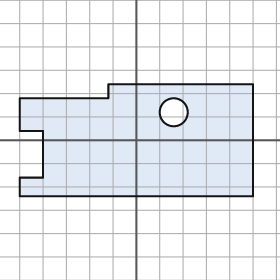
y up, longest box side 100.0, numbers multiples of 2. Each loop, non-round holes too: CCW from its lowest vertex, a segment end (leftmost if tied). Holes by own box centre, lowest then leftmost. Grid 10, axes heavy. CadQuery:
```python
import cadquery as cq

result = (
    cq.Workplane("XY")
    .moveTo(-50.0, -24.0)
    .lineTo(50.0, -24.0)
    .lineTo(50.0, 24.0)
    .lineTo(-12.0, 24.0)
    .lineTo(-12.0, 18.0)
    .lineTo(-50.0, 18.0)
    .lineTo(-50.0, 4.0)
    .lineTo(-40.0, 4.0)
    .lineTo(-40.0, -16.0)
    .lineTo(-50.0, -16.0)
    .close()
    .moveTo(16.0, 12.0)
    .circle(6.0)
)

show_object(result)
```